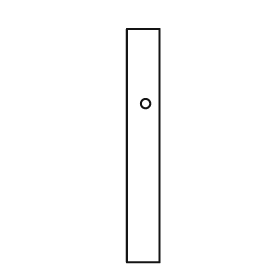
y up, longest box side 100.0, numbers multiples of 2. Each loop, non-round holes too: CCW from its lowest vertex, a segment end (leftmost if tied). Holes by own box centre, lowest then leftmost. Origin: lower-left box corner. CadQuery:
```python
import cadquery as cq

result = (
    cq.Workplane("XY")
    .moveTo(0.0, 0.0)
    .lineTo(14.0, 0.0)
    .lineTo(14.0, 100.0)
    .lineTo(0.0, 100.0)
    .close()
    .moveTo(8.0, 68.0)
    .circle(2.0)
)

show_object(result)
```